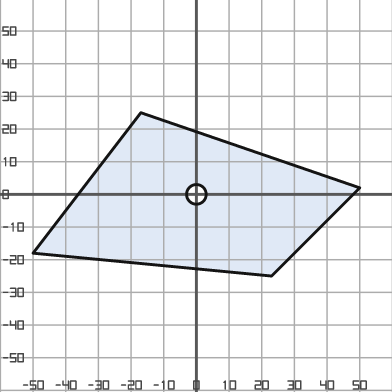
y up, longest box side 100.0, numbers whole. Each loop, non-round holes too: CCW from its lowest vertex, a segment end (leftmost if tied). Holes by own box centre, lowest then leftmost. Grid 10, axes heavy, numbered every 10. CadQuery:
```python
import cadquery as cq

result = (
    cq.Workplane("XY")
    .moveTo(23.0, -25.0)
    .lineTo(50.0, 2.0)
    .lineTo(-17.0, 25.0)
    .lineTo(-50.0, -18.0)
    .close()
    .moveTo(0.0, 0.0)
    .circle(3.0)
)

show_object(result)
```